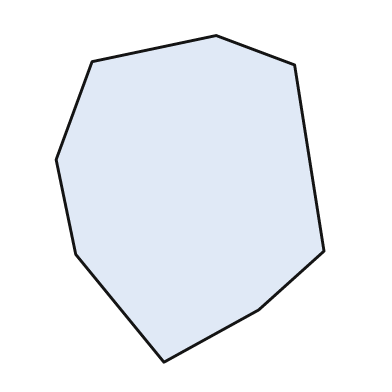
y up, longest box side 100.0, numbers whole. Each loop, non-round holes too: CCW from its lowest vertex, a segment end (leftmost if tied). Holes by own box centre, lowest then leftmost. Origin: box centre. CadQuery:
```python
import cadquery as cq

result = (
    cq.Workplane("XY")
    .moveTo(-8.0, -50.0)
    .lineTo(21.0, -34.0)
    .lineTo(41.0, -16.0)
    .lineTo(32.0, 41.0)
    .lineTo(8.0, 50.0)
    .lineTo(-30.0, 42.0)
    .lineTo(-41.0, 12.0)
    .lineTo(-35.0, -17.0)
    .close()
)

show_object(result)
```